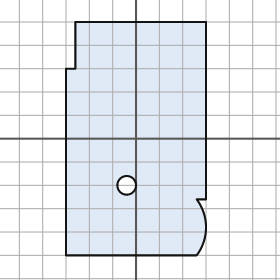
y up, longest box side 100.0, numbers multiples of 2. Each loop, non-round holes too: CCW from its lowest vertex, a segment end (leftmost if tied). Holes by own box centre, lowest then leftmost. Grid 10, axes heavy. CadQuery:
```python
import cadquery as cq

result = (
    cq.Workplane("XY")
    .moveTo(-30.0, -50.0)
    .lineTo(26.0, -50.0)
    .threePointArc((30.0, -38.0), (26.0, -26.0))
    .lineTo(30.0, -26.0)
    .lineTo(30.0, 50.0)
    .lineTo(-26.0, 50.0)
    .lineTo(-26.0, 30.0)
    .lineTo(-30.0, 30.0)
    .close()
    .moveTo(-4.0, -20.0)
    .circle(4.0)
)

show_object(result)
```